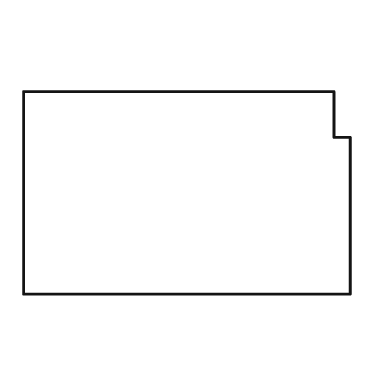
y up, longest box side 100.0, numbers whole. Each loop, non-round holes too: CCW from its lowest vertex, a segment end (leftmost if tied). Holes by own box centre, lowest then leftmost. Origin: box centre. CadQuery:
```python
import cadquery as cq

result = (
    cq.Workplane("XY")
    .moveTo(-50.0, -31.0)
    .lineTo(50.0, -31.0)
    .lineTo(50.0, 17.0)
    .lineTo(45.0, 17.0)
    .lineTo(45.0, 31.0)
    .lineTo(-50.0, 31.0)
    .close()
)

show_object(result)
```